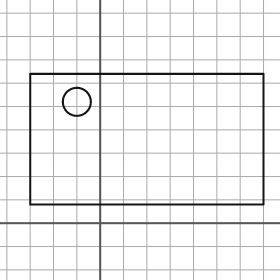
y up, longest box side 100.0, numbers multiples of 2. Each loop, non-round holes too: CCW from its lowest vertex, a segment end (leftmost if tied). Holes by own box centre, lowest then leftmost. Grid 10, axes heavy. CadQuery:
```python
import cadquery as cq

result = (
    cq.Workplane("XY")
    .moveTo(-30.0, 8.0)
    .lineTo(70.0, 8.0)
    .lineTo(70.0, 64.0)
    .lineTo(-30.0, 64.0)
    .close()
    .moveTo(-10.0, 52.0)
    .circle(6.0)
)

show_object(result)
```